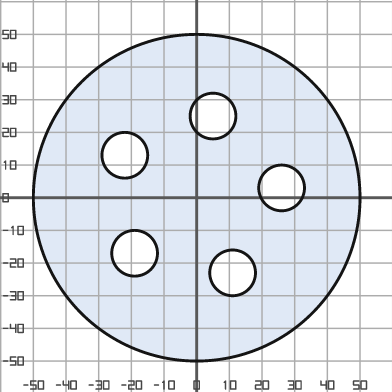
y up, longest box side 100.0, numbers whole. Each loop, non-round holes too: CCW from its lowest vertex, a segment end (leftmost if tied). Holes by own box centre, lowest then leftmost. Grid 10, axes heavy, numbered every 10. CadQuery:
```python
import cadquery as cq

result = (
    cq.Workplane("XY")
    .moveTo(0.0, 0.0)
    .circle(50.0)
    .moveTo(11.0, -23.0)
    .circle(7.0)
    .moveTo(-19.0, -17.0)
    .circle(7.0)
    .moveTo(26.0, 3.0)
    .circle(7.0)
    .moveTo(-22.0, 13.0)
    .circle(7.0)
    .moveTo(5.0, 25.0)
    .circle(7.0)
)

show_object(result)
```